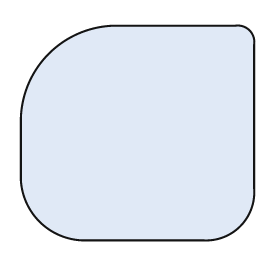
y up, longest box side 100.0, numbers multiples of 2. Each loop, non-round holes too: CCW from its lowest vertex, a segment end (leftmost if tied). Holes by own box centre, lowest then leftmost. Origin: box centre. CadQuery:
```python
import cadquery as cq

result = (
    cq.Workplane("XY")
    .moveTo(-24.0, -46.0)
    .lineTo(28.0, -46.0)
    .threePointArc((44.0, -40.0), (50.0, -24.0))
    .lineTo(50.0, 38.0)
    .threePointArc((48.0, 44.0), (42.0, 46.0))
    .lineTo(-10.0, 46.0)
    .threePointArc((-38.0, 34.0), (-50.0, 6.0))
    .lineTo(-50.0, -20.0)
    .threePointArc((-42.0, -38.0), (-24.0, -46.0))
    .close()
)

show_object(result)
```